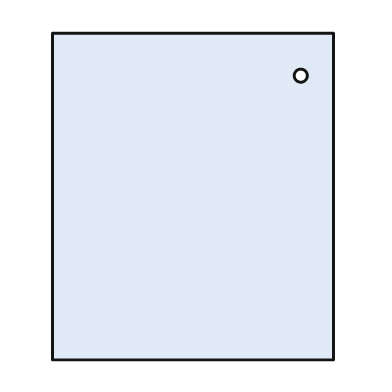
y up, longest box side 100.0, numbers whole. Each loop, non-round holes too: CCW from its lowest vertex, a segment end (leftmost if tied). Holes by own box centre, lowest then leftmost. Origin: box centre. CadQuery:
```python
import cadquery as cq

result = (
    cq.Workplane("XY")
    .moveTo(-43.0, -50.0)
    .lineTo(43.0, -50.0)
    .lineTo(43.0, 50.0)
    .lineTo(-43.0, 50.0)
    .close()
    .moveTo(33.0, 37.0)
    .circle(2.0)
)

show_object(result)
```